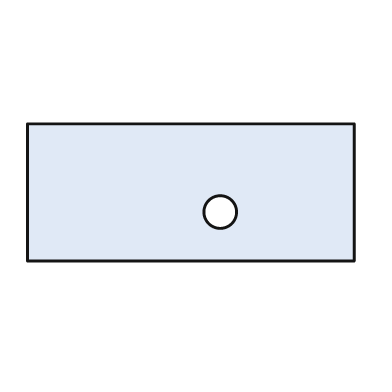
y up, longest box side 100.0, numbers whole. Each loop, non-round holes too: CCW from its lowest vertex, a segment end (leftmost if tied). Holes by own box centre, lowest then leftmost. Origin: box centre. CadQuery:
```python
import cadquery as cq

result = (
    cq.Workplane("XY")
    .moveTo(-50.0, -21.0)
    .lineTo(50.0, -21.0)
    .lineTo(50.0, 21.0)
    .lineTo(-50.0, 21.0)
    .close()
    .moveTo(9.0, -6.0)
    .circle(5.0)
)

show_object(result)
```